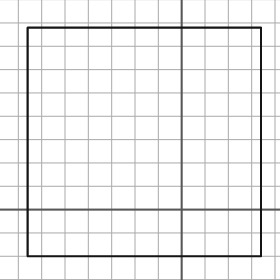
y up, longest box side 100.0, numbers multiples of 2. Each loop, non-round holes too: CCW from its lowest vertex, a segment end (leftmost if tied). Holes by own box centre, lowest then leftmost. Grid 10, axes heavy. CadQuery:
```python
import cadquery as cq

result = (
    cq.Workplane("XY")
    .moveTo(-66.0, -20.0)
    .lineTo(34.0, -20.0)
    .lineTo(34.0, 78.0)
    .lineTo(-66.0, 78.0)
    .close()
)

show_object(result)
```